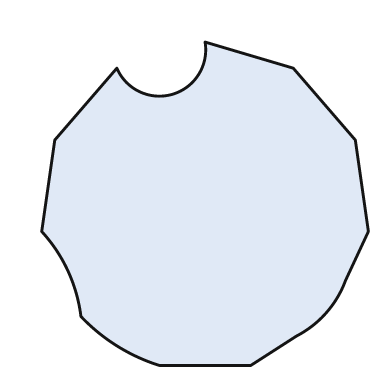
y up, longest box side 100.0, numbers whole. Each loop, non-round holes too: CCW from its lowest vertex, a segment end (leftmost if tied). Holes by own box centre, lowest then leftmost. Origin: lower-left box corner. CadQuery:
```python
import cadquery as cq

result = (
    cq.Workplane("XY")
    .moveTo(36.0, 0.0)
    .lineTo(64.0, 0.0)
    .lineTo(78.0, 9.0)
    .threePointArc((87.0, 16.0), (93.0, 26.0))
    .lineTo(100.0, 41.0)
    .lineTo(96.0, 69.0)
    .lineTo(77.0, 91.0)
    .lineTo(50.0, 99.0)
    .threePointArc((40.0, 83.0), (23.0, 91.0))
    .lineTo(4.0, 69.0)
    .lineTo(0.0, 41.0)
    .threePointArc((8.0, 29.0), (12.0, 15.0))
    .threePointArc((23.0, 6.0), (36.0, 0.0))
    .close()
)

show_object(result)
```